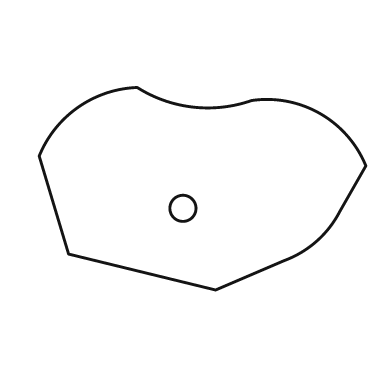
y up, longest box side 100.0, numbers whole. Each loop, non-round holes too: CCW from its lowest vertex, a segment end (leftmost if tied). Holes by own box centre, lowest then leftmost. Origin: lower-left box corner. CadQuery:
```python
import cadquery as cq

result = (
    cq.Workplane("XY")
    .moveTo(54.0, 0.0)
    .lineTo(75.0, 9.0)
    .threePointArc((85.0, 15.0), (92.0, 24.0))
    .lineTo(100.0, 38.0)
    .threePointArc((86.0, 54.0), (65.0, 58.0))
    .threePointArc((47.0, 56.0), (30.0, 62.0))
    .threePointArc((12.0, 56.0), (0.0, 41.0))
    .lineTo(9.0, 11.0)
    .close()
    .moveTo(44.0, 25.0)
    .circle(4.0)
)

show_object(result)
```